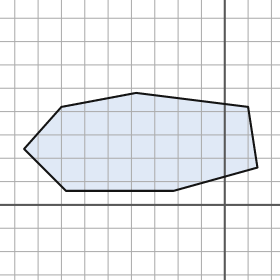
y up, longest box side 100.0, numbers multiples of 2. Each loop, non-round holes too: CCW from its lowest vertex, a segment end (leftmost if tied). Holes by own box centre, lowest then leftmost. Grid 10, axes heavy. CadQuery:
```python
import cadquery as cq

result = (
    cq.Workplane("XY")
    .moveTo(-68.0, 6.0)
    .lineTo(-22.0, 6.0)
    .lineTo(14.0, 16.0)
    .lineTo(10.0, 42.0)
    .lineTo(-38.0, 48.0)
    .lineTo(-70.0, 42.0)
    .lineTo(-86.0, 24.0)
    .close()
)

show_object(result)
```